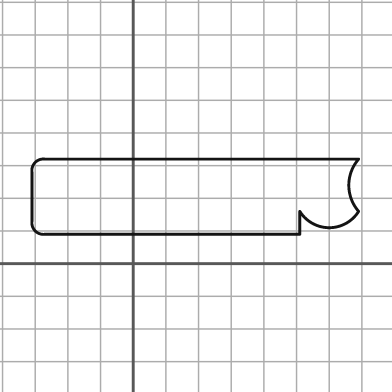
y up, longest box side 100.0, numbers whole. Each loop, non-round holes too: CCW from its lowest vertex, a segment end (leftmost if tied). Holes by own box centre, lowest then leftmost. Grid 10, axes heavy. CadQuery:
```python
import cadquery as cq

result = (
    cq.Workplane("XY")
    .moveTo(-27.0, 9.0)
    .lineTo(51.0, 9.0)
    .lineTo(51.0, 16.0)
    .threePointArc((60.0, 11.0), (69.0, 16.0))
    .threePointArc((66.0, 24.0), (69.0, 32.0))
    .lineTo(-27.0, 32.0)
    .threePointArc((-30.0, 31.0), (-31.0, 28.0))
    .lineTo(-31.0, 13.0)
    .threePointArc((-30.0, 10.0), (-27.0, 9.0))
    .close()
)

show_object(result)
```